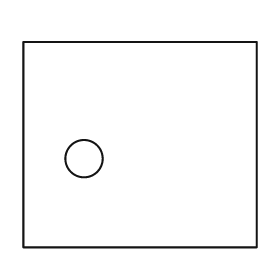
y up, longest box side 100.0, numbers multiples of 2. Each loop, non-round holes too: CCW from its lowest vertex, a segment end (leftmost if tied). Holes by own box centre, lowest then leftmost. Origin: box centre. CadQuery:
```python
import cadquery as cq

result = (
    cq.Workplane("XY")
    .moveTo(-50.0, -44.0)
    .lineTo(50.0, -44.0)
    .lineTo(50.0, 44.0)
    .lineTo(-50.0, 44.0)
    .close()
    .moveTo(-24.0, -6.0)
    .circle(8.0)
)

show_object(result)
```